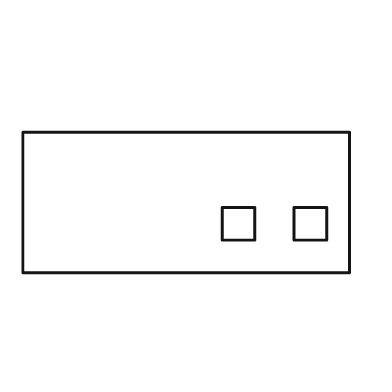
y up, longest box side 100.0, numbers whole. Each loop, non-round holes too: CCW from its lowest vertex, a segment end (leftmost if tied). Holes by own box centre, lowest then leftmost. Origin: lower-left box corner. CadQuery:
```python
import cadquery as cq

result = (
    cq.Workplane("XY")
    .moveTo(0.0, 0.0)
    .lineTo(100.0, 0.0)
    .lineTo(100.0, 43.0)
    .lineTo(0.0, 43.0)
    .close()
    .moveTo(61.0, 10.0)
    .lineTo(71.0, 10.0)
    .lineTo(71.0, 20.0)
    .lineTo(61.0, 20.0)
    .close()
    .moveTo(83.0, 10.0)
    .lineTo(93.0, 10.0)
    .lineTo(93.0, 20.0)
    .lineTo(83.0, 20.0)
    .close()
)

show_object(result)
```